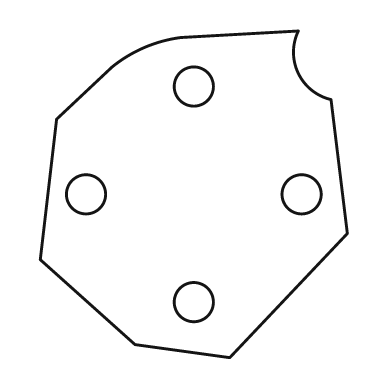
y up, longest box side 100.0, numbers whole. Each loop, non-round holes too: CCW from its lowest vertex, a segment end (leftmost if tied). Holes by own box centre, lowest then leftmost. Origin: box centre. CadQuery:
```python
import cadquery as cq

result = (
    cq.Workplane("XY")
    .moveTo(11.0, -50.0)
    .lineTo(47.0, -12.0)
    .lineTo(42.0, 29.0)
    .threePointArc((32.0, 37.0), (32.0, 50.0))
    .lineTo(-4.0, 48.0)
    .threePointArc((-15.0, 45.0), (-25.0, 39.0))
    .lineTo(-42.0, 23.0)
    .lineTo(-47.0, -20.0)
    .lineTo(-18.0, -46.0)
    .close()
    .moveTo(0.0, -33.0)
    .circle(6.0)
    .moveTo(-33.0, 0.0)
    .circle(6.0)
    .moveTo(33.0, 0.0)
    .circle(6.0)
    .moveTo(0.0, 33.0)
    .circle(6.0)
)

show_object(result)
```